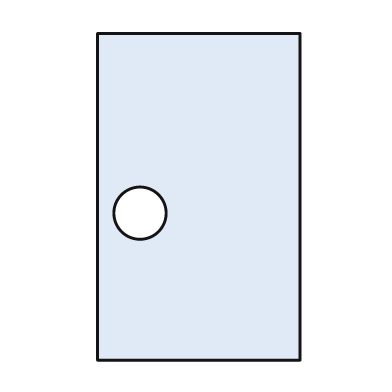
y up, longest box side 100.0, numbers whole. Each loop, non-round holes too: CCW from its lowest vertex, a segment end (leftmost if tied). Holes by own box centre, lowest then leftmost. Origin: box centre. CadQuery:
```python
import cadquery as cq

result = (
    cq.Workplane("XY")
    .moveTo(-31.0, -50.0)
    .lineTo(31.0, -50.0)
    .lineTo(31.0, 50.0)
    .lineTo(-31.0, 50.0)
    .close()
    .moveTo(-18.0, -5.0)
    .circle(8.0)
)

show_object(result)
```